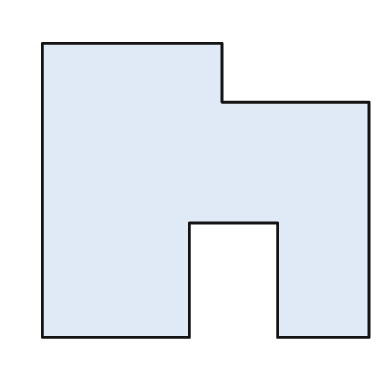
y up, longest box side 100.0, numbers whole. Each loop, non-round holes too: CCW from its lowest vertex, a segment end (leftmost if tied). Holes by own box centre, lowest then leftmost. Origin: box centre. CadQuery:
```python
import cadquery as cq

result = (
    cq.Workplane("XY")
    .moveTo(-50.0, -45.0)
    .lineTo(-5.0, -45.0)
    .lineTo(-5.0, -10.0)
    .lineTo(22.0, -10.0)
    .lineTo(22.0, -45.0)
    .lineTo(50.0, -45.0)
    .lineTo(50.0, 27.0)
    .lineTo(5.0, 27.0)
    .lineTo(5.0, 45.0)
    .lineTo(-50.0, 45.0)
    .close()
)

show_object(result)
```